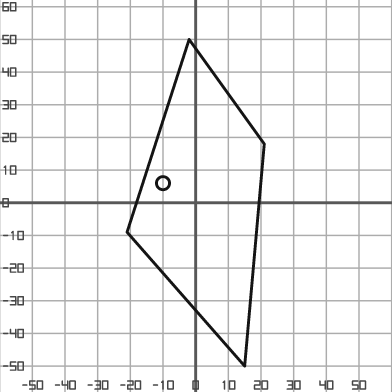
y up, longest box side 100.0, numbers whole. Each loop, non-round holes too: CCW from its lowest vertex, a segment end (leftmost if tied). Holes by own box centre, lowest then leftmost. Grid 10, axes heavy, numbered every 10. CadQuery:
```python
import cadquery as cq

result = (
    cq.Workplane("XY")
    .moveTo(15.0, -50.0)
    .lineTo(21.0, 18.0)
    .lineTo(-2.0, 50.0)
    .lineTo(-21.0, -9.0)
    .close()
    .moveTo(-10.0, 6.0)
    .circle(2.0)
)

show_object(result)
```